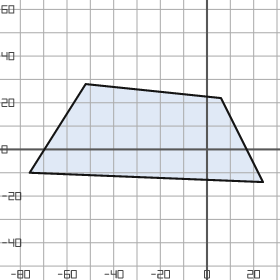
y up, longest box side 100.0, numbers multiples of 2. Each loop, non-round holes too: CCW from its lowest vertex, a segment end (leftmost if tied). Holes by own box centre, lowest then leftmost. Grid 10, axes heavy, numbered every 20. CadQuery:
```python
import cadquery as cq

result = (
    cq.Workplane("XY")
    .moveTo(24.0, -14.0)
    .lineTo(6.0, 22.0)
    .lineTo(-52.0, 28.0)
    .lineTo(-76.0, -10.0)
    .close()
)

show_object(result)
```